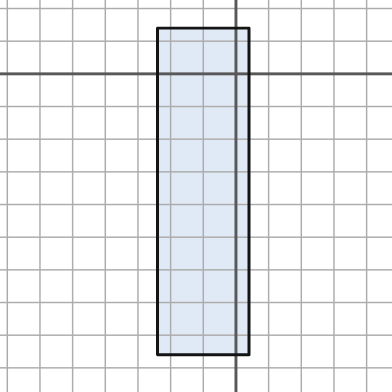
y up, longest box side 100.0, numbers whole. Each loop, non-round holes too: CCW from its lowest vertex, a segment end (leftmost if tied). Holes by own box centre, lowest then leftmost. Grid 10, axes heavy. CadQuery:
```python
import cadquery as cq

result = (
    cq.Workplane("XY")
    .moveTo(-24.0, -86.0)
    .lineTo(4.0, -86.0)
    .lineTo(4.0, 14.0)
    .lineTo(-24.0, 14.0)
    .close()
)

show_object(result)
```